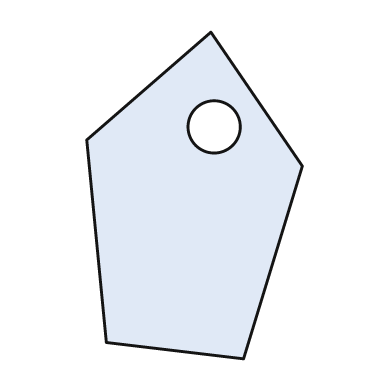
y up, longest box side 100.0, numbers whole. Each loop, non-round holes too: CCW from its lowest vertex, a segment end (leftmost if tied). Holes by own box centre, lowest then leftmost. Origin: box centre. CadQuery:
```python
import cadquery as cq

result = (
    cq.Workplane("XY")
    .moveTo(15.0, -50.0)
    .lineTo(33.0, 9.0)
    .lineTo(5.0, 50.0)
    .lineTo(-33.0, 17.0)
    .lineTo(-27.0, -45.0)
    .close()
    .moveTo(6.0, 21.0)
    .circle(8.0)
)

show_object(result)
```